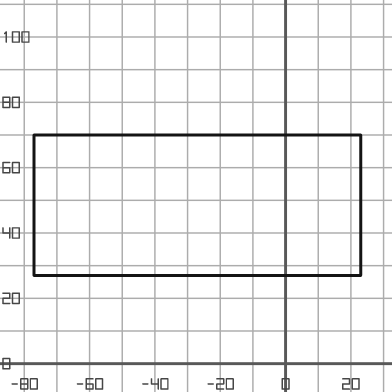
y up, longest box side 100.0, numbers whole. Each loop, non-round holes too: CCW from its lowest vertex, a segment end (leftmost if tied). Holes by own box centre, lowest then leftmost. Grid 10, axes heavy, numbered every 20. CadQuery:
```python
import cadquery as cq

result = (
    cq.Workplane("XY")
    .moveTo(-77.0, 27.0)
    .lineTo(23.0, 27.0)
    .lineTo(23.0, 70.0)
    .lineTo(-77.0, 70.0)
    .close()
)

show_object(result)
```